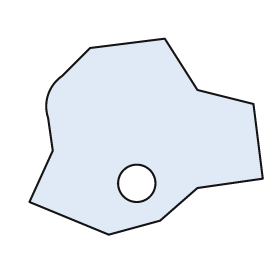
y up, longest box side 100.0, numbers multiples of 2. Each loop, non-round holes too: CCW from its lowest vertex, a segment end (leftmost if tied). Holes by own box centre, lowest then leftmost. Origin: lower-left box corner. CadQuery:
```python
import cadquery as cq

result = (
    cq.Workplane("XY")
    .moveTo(34.0, 0.0)
    .lineTo(56.0, 6.0)
    .lineTo(72.0, 20.0)
    .lineTo(100.0, 24.0)
    .lineTo(96.0, 56.0)
    .lineTo(72.0, 62.0)
    .lineTo(58.0, 84.0)
    .lineTo(26.0, 80.0)
    .lineTo(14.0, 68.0)
    .threePointArc((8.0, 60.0), (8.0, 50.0))
    .lineTo(10.0, 36.0)
    .lineTo(0.0, 14.0)
    .close()
    .moveTo(46.0, 22.0)
    .circle(8.0)
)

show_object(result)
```